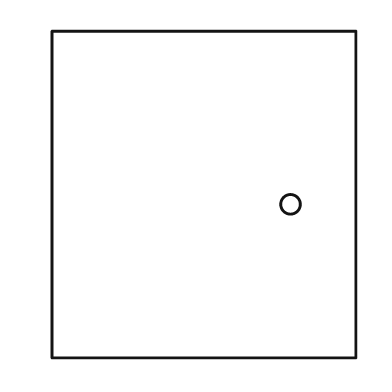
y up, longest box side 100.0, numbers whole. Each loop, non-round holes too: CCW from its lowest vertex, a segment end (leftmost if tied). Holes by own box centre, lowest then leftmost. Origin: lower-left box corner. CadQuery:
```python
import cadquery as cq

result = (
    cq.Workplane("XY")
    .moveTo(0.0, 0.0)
    .lineTo(93.0, 0.0)
    .lineTo(93.0, 100.0)
    .lineTo(0.0, 100.0)
    .close()
    .moveTo(73.0, 47.0)
    .circle(3.0)
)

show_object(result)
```